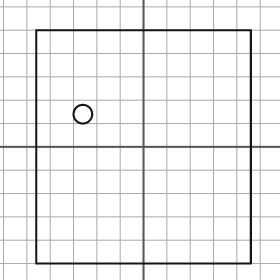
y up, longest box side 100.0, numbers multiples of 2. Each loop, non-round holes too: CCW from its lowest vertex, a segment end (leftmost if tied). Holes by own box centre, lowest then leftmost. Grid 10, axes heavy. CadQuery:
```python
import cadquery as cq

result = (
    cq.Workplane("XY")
    .moveTo(-46.0, -50.0)
    .lineTo(46.0, -50.0)
    .lineTo(46.0, 50.0)
    .lineTo(-46.0, 50.0)
    .close()
    .moveTo(-26.0, 14.0)
    .circle(4.0)
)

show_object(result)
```